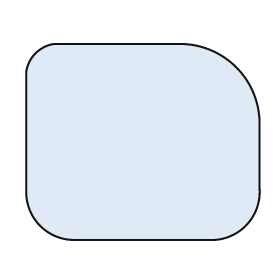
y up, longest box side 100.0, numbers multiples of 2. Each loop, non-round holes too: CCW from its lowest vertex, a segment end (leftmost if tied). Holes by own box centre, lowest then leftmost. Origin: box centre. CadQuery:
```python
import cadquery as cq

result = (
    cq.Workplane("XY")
    .moveTo(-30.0, -42.0)
    .lineTo(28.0, -42.0)
    .threePointArc((44.0, -36.0), (50.0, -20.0))
    .lineTo(50.0, 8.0)
    .threePointArc((40.0, 32.0), (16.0, 42.0))
    .lineTo(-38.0, 42.0)
    .threePointArc((-46.0, 38.0), (-50.0, 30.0))
    .lineTo(-50.0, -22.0)
    .threePointArc((-44.0, -36.0), (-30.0, -42.0))
    .close()
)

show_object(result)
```